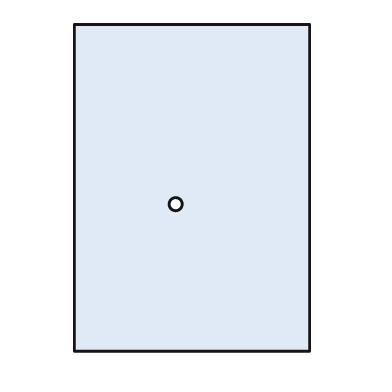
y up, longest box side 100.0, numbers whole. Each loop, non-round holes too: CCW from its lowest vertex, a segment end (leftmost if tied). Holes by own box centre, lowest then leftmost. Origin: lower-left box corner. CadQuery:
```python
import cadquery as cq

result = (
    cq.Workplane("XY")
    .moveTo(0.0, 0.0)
    .lineTo(72.0, 0.0)
    .lineTo(72.0, 100.0)
    .lineTo(0.0, 100.0)
    .close()
    .moveTo(31.0, 45.0)
    .circle(2.0)
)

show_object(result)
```